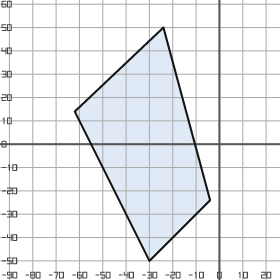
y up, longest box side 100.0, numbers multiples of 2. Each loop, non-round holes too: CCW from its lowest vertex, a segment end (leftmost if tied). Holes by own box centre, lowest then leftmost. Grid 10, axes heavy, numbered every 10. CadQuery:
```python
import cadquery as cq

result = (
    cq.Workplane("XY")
    .moveTo(-30.0, -50.0)
    .lineTo(-4.0, -24.0)
    .lineTo(-24.0, 50.0)
    .lineTo(-62.0, 14.0)
    .close()
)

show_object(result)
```